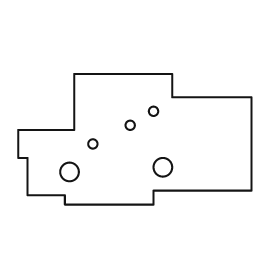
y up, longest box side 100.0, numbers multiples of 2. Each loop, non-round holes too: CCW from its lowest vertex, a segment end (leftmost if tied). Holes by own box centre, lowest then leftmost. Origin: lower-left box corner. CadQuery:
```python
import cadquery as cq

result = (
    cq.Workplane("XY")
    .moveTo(20.0, 0.0)
    .lineTo(58.0, 0.0)
    .lineTo(58.0, 6.0)
    .lineTo(100.0, 6.0)
    .lineTo(100.0, 46.0)
    .lineTo(66.0, 46.0)
    .lineTo(66.0, 56.0)
    .lineTo(24.0, 56.0)
    .lineTo(24.0, 32.0)
    .lineTo(0.0, 32.0)
    .lineTo(0.0, 20.0)
    .lineTo(4.0, 20.0)
    .lineTo(4.0, 4.0)
    .lineTo(20.0, 4.0)
    .close()
    .moveTo(22.0, 14.0)
    .circle(4.0)
    .moveTo(62.0, 16.0)
    .circle(4.0)
    .moveTo(32.0, 26.0)
    .circle(2.0)
    .moveTo(48.0, 34.0)
    .circle(2.0)
    .moveTo(58.0, 40.0)
    .circle(2.0)
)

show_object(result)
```